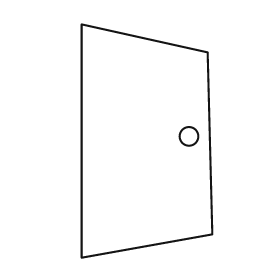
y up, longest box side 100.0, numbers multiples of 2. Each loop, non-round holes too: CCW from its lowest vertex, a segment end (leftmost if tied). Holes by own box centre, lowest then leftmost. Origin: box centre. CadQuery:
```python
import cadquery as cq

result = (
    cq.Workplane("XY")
    .moveTo(-28.0, -50.0)
    .lineTo(28.0, -40.0)
    .lineTo(26.0, 38.0)
    .lineTo(-28.0, 50.0)
    .close()
    .moveTo(18.0, 2.0)
    .circle(4.0)
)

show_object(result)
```